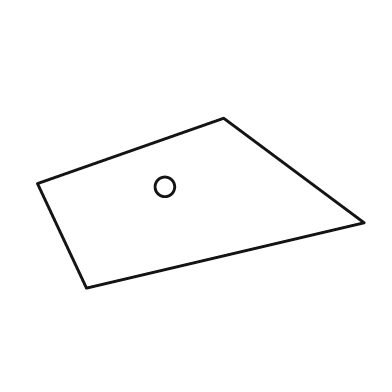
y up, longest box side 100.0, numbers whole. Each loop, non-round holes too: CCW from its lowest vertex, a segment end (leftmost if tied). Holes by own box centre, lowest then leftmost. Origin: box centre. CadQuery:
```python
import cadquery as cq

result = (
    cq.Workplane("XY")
    .moveTo(-35.0, -26.0)
    .lineTo(50.0, -6.0)
    .lineTo(7.0, 26.0)
    .lineTo(-50.0, 6.0)
    .close()
    .moveTo(-11.0, 5.0)
    .circle(3.0)
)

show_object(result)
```